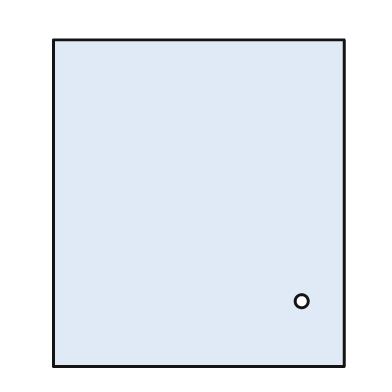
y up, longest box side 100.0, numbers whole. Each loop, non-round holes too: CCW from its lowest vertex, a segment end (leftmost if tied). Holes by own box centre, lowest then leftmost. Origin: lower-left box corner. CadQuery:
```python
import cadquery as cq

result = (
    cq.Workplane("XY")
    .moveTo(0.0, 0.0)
    .lineTo(89.0, 0.0)
    .lineTo(89.0, 100.0)
    .lineTo(0.0, 100.0)
    .close()
    .moveTo(76.0, 20.0)
    .circle(2.0)
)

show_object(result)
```